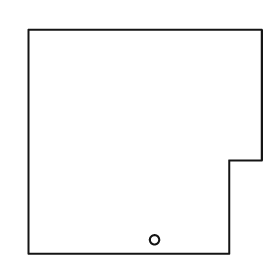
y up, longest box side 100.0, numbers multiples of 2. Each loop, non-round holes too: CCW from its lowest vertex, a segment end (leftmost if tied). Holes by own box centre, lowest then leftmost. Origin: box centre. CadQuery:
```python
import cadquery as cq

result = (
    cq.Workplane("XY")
    .moveTo(-50.0, -48.0)
    .lineTo(36.0, -48.0)
    .lineTo(36.0, -8.0)
    .lineTo(50.0, -8.0)
    .lineTo(50.0, 48.0)
    .lineTo(-50.0, 48.0)
    .close()
    .moveTo(4.0, -42.0)
    .circle(2.0)
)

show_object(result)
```